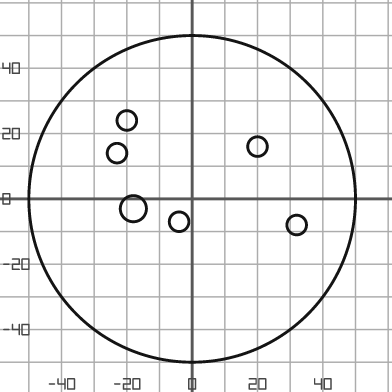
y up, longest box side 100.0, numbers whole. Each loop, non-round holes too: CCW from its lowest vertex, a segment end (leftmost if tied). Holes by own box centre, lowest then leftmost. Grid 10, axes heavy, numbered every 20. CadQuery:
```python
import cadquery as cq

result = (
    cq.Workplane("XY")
    .moveTo(0.0, 0.0)
    .circle(50.0)
    .moveTo(32.0, -8.0)
    .circle(3.0)
    .moveTo(-4.0, -7.0)
    .circle(3.0)
    .moveTo(-18.0, -3.0)
    .circle(4.0)
    .moveTo(-23.0, 14.0)
    .circle(3.0)
    .moveTo(20.0, 16.0)
    .circle(3.0)
    .moveTo(-20.0, 24.0)
    .circle(3.0)
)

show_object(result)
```